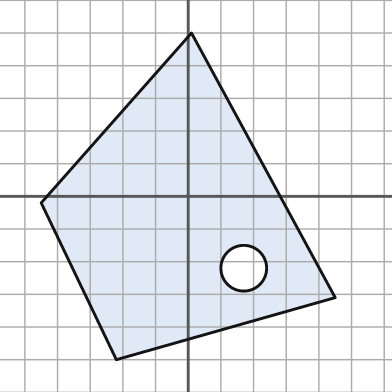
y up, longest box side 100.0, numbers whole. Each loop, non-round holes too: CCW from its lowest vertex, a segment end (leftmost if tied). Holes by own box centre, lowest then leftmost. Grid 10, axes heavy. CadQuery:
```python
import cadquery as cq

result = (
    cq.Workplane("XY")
    .moveTo(-22.0, -50.0)
    .lineTo(45.0, -31.0)
    .lineTo(1.0, 50.0)
    .lineTo(-45.0, -2.0)
    .close()
    .moveTo(17.0, -22.0)
    .circle(7.0)
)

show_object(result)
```